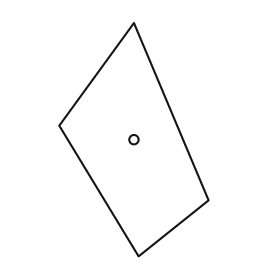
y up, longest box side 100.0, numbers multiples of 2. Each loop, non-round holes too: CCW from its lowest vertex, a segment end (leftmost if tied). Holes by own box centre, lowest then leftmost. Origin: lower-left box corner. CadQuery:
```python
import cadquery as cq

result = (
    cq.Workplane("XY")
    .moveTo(34.0, 0.0)
    .lineTo(64.0, 24.0)
    .lineTo(32.0, 100.0)
    .lineTo(0.0, 56.0)
    .close()
    .moveTo(32.0, 50.0)
    .circle(2.0)
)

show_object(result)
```